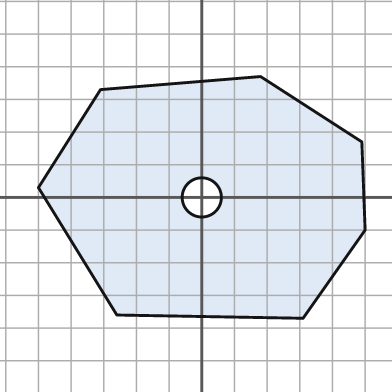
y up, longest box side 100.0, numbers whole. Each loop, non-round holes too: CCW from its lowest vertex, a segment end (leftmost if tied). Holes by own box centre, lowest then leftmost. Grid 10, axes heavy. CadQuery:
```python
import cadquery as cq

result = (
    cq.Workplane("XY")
    .moveTo(31.0, -37.0)
    .lineTo(50.0, -10.0)
    .lineTo(49.0, 17.0)
    .lineTo(18.0, 37.0)
    .lineTo(-31.0, 33.0)
    .lineTo(-50.0, 3.0)
    .lineTo(-26.0, -36.0)
    .close()
    .moveTo(0.0, 0.0)
    .circle(6.0)
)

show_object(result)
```